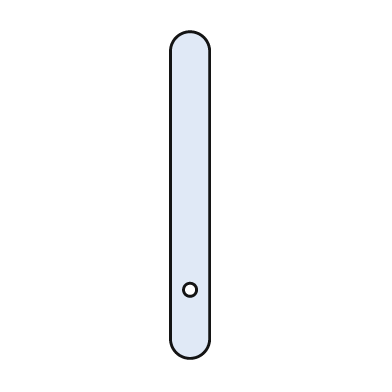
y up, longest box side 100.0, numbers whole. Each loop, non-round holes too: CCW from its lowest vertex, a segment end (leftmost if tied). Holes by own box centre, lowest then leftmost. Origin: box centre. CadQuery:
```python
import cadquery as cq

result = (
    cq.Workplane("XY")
    .moveTo(-6.0, -44.0)
    .threePointArc((0.0, -50.0), (6.0, -44.0))
    .lineTo(6.0, 44.0)
    .threePointArc((0.0, 50.0), (-6.0, 44.0))
    .close()
    .moveTo(0.0, -29.0)
    .circle(2.0)
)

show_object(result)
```